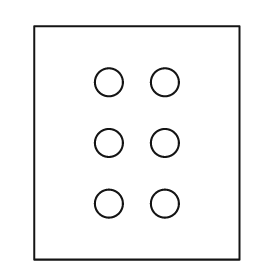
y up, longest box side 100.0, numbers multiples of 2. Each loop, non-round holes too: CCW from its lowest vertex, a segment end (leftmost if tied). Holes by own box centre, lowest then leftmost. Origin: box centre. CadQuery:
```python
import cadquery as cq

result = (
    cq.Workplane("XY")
    .moveTo(-44.0, -50.0)
    .lineTo(44.0, -50.0)
    .lineTo(44.0, 50.0)
    .lineTo(-44.0, 50.0)
    .close()
    .moveTo(-12.0, -26.0)
    .circle(6.0)
    .moveTo(12.0, -26.0)
    .circle(6.0)
    .moveTo(-12.0, 0.0)
    .circle(6.0)
    .moveTo(12.0, 0.0)
    .circle(6.0)
    .moveTo(-12.0, 26.0)
    .circle(6.0)
    .moveTo(12.0, 26.0)
    .circle(6.0)
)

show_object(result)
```